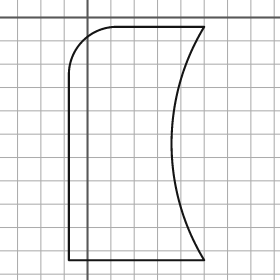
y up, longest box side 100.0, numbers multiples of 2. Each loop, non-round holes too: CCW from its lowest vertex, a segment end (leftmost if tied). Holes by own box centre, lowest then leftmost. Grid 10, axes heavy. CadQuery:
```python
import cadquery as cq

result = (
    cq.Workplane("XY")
    .moveTo(-8.0, -104.0)
    .lineTo(50.0, -104.0)
    .threePointArc((36.0, -54.0), (50.0, -4.0))
    .lineTo(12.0, -4.0)
    .threePointArc((-2.0, -10.0), (-8.0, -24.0))
    .close()
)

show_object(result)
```